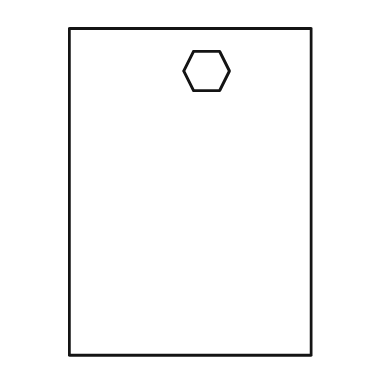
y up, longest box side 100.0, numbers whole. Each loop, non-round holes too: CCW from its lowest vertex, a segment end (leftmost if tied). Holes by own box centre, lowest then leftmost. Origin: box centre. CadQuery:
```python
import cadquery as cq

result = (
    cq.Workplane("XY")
    .moveTo(-37.0, -50.0)
    .lineTo(37.0, -50.0)
    .lineTo(37.0, 50.0)
    .lineTo(-37.0, 50.0)
    .close()
    .moveTo(1.0, 31.0)
    .lineTo(9.0, 31.0)
    .lineTo(12.0, 37.0)
    .lineTo(9.0, 43.0)
    .lineTo(1.0, 43.0)
    .lineTo(-2.0, 37.0)
    .close()
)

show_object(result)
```